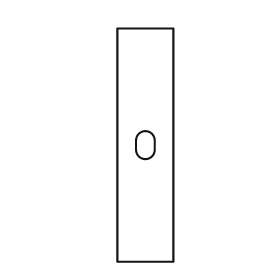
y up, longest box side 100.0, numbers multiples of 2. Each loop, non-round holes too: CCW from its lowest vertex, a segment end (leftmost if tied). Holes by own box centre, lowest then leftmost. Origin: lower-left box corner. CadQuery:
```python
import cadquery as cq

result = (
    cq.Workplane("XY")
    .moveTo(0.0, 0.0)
    .lineTo(24.0, 0.0)
    .lineTo(24.0, 100.0)
    .lineTo(0.0, 100.0)
    .close()
    .moveTo(8.0, 48.0)
    .threePointArc((12.0, 44.0), (16.0, 48.0))
    .lineTo(16.0, 52.0)
    .threePointArc((12.0, 56.0), (8.0, 52.0))
    .close()
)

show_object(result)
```